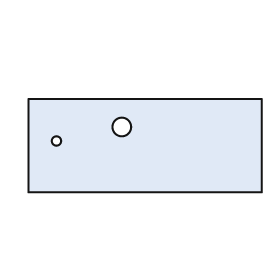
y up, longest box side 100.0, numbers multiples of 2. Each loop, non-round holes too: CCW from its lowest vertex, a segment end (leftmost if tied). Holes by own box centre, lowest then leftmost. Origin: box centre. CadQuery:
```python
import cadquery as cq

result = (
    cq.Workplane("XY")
    .moveTo(-50.0, -20.0)
    .lineTo(50.0, -20.0)
    .lineTo(50.0, 20.0)
    .lineTo(-50.0, 20.0)
    .close()
    .moveTo(-38.0, 2.0)
    .circle(2.0)
    .moveTo(-10.0, 8.0)
    .circle(4.0)
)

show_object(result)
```